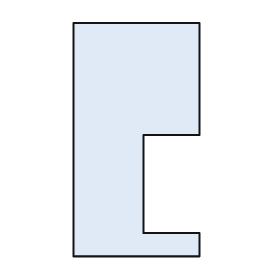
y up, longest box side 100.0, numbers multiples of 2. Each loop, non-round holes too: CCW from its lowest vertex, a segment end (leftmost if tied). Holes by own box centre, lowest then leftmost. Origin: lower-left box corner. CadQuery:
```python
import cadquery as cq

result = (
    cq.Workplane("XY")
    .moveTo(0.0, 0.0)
    .lineTo(54.0, 0.0)
    .lineTo(54.0, 10.0)
    .lineTo(30.0, 10.0)
    .lineTo(30.0, 52.0)
    .lineTo(54.0, 52.0)
    .lineTo(54.0, 100.0)
    .lineTo(0.0, 100.0)
    .close()
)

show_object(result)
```